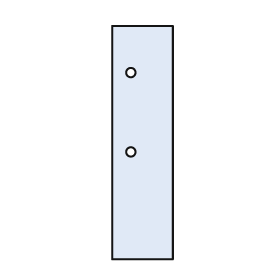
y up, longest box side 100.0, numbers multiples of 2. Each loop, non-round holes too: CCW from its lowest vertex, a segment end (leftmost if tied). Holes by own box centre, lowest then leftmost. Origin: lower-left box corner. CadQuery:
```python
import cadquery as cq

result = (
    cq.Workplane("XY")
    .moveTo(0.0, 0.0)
    .lineTo(26.0, 0.0)
    .lineTo(26.0, 100.0)
    .lineTo(0.0, 100.0)
    .close()
    .moveTo(8.0, 46.0)
    .circle(2.0)
    .moveTo(8.0, 80.0)
    .circle(2.0)
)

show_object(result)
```